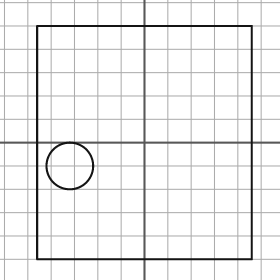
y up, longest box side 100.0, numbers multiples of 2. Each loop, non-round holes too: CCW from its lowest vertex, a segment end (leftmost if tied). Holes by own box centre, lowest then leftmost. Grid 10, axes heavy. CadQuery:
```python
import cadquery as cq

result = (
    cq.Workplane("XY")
    .moveTo(-46.0, -50.0)
    .lineTo(46.0, -50.0)
    .lineTo(46.0, 50.0)
    .lineTo(-46.0, 50.0)
    .close()
    .moveTo(-32.0, -10.0)
    .circle(10.0)
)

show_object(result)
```